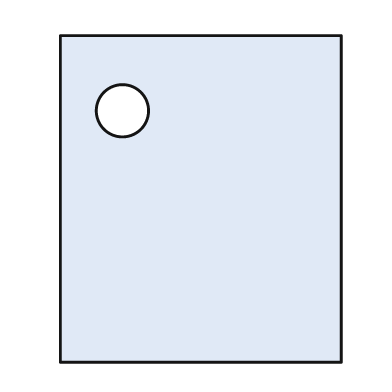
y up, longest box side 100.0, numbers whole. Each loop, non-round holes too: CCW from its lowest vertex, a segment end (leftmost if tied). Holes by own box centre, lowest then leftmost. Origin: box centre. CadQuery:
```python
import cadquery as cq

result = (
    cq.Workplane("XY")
    .moveTo(-43.0, -50.0)
    .lineTo(43.0, -50.0)
    .lineTo(43.0, 50.0)
    .lineTo(-43.0, 50.0)
    .close()
    .moveTo(-24.0, 27.0)
    .circle(8.0)
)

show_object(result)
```